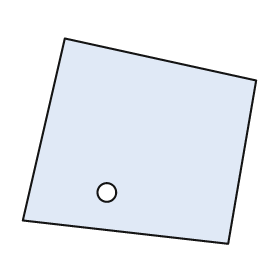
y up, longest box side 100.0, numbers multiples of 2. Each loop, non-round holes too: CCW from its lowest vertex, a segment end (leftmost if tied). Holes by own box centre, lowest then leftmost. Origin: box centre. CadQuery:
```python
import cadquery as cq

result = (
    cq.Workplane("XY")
    .moveTo(38.0, -44.0)
    .lineTo(50.0, 26.0)
    .lineTo(-32.0, 44.0)
    .lineTo(-50.0, -34.0)
    .close()
    .moveTo(-14.0, -22.0)
    .circle(4.0)
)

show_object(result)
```